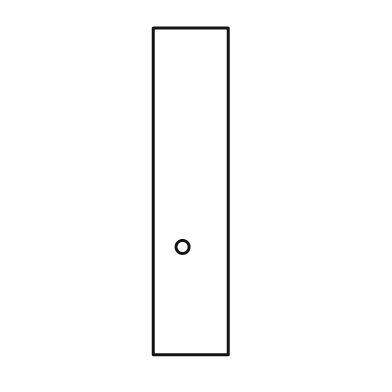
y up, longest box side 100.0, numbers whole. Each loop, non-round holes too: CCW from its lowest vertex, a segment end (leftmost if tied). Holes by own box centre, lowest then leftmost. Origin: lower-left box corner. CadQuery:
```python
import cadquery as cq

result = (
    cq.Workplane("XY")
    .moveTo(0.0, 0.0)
    .lineTo(23.0, 0.0)
    .lineTo(23.0, 100.0)
    .lineTo(0.0, 100.0)
    .close()
    .moveTo(9.0, 33.0)
    .circle(2.0)
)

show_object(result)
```